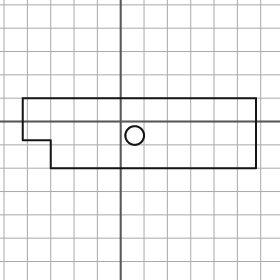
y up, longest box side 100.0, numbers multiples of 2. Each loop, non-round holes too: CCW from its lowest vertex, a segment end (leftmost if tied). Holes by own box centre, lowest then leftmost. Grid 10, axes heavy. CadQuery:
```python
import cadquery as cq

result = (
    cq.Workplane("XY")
    .moveTo(-30.0, -20.0)
    .lineTo(58.0, -20.0)
    .lineTo(58.0, 10.0)
    .lineTo(-42.0, 10.0)
    .lineTo(-42.0, -8.0)
    .lineTo(-30.0, -8.0)
    .close()
    .moveTo(6.0, -6.0)
    .circle(4.0)
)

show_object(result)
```